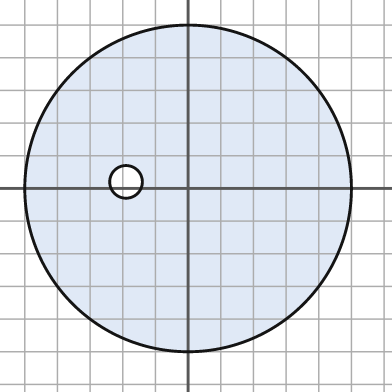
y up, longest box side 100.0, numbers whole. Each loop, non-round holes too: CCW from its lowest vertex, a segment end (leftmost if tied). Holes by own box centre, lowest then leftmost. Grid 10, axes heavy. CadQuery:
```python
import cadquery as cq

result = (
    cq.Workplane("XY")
    .moveTo(0.0, 0.0)
    .circle(50.0)
    .moveTo(-19.0, 2.0)
    .circle(5.0)
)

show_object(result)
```